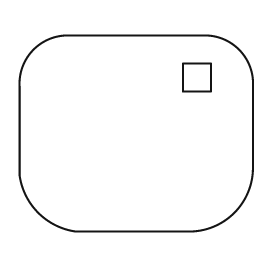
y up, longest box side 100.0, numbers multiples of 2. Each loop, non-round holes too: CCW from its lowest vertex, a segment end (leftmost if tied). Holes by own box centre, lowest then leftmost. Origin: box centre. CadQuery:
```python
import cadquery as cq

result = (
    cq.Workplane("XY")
    .moveTo(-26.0, -42.0)
    .lineTo(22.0, -42.0)
    .threePointArc((42.0, -34.0), (50.0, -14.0))
    .lineTo(50.0, 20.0)
    .threePointArc((44.0, 36.0), (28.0, 42.0))
    .lineTo(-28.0, 42.0)
    .threePointArc((-44.0, 36.0), (-50.0, 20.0))
    .lineTo(-50.0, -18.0)
    .threePointArc((-42.0, -34.0), (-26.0, -42.0))
    .close()
    .moveTo(20.0, 18.0)
    .lineTo(32.0, 18.0)
    .lineTo(32.0, 30.0)
    .lineTo(20.0, 30.0)
    .close()
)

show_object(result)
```